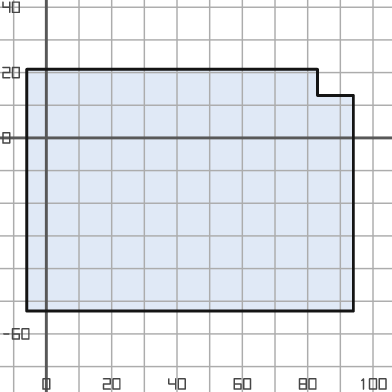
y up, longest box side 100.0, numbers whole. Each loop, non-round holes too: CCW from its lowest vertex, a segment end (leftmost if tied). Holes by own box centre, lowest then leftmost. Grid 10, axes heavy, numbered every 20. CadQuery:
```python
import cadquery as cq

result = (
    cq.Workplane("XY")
    .moveTo(-6.0, -53.0)
    .lineTo(94.0, -53.0)
    .lineTo(94.0, 13.0)
    .lineTo(83.0, 13.0)
    .lineTo(83.0, 21.0)
    .lineTo(-6.0, 21.0)
    .close()
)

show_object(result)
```